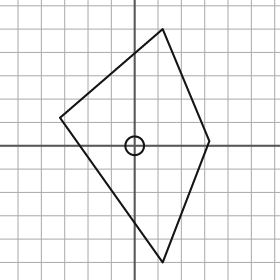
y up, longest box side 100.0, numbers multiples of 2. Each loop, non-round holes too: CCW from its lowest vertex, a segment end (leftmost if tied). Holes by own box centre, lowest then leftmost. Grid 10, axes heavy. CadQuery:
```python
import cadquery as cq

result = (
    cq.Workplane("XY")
    .moveTo(12.0, -50.0)
    .lineTo(32.0, 2.0)
    .lineTo(12.0, 50.0)
    .lineTo(-32.0, 12.0)
    .close()
    .moveTo(0.0, 0.0)
    .circle(4.0)
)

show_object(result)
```